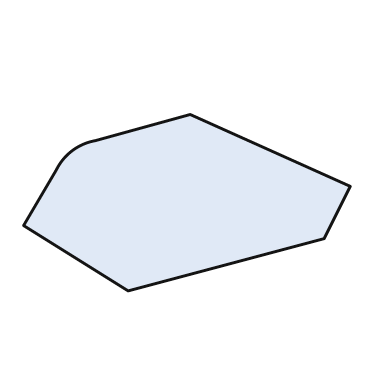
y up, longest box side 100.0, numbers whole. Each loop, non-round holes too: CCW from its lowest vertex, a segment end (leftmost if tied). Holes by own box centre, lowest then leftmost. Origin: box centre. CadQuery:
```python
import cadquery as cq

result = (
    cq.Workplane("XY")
    .moveTo(-18.0, -27.0)
    .lineTo(42.0, -11.0)
    .lineTo(50.0, 5.0)
    .lineTo(1.0, 27.0)
    .lineTo(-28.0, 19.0)
    .threePointArc((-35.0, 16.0), (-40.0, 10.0))
    .lineTo(-50.0, -7.0)
    .close()
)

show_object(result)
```